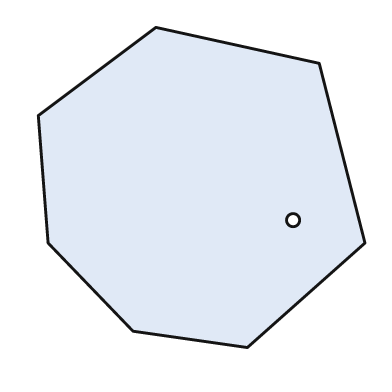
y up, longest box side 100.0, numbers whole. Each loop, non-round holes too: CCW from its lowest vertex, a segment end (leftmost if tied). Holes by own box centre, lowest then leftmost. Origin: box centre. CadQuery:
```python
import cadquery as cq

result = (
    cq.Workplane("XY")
    .moveTo(14.0, -49.0)
    .lineTo(50.0, -17.0)
    .lineTo(36.0, 38.0)
    .lineTo(-14.0, 49.0)
    .lineTo(-50.0, 22.0)
    .lineTo(-47.0, -17.0)
    .lineTo(-21.0, -44.0)
    .close()
    .moveTo(28.0, -10.0)
    .circle(2.0)
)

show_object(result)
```